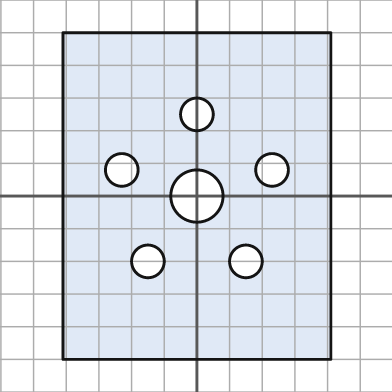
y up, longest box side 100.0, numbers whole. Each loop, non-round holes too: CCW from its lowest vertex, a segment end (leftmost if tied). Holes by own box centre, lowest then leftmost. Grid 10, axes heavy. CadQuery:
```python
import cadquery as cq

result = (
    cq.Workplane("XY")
    .moveTo(-41.0, -50.0)
    .lineTo(41.0, -50.0)
    .lineTo(41.0, 50.0)
    .lineTo(-41.0, 50.0)
    .close()
    .moveTo(-15.0, -20.0)
    .circle(5.0)
    .moveTo(15.0, -20.0)
    .circle(5.0)
    .moveTo(0.0, 0.0)
    .circle(8.0)
    .moveTo(-23.0, 8.0)
    .circle(5.0)
    .moveTo(23.0, 8.0)
    .circle(5.0)
    .moveTo(0.0, 25.0)
    .circle(5.0)
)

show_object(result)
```